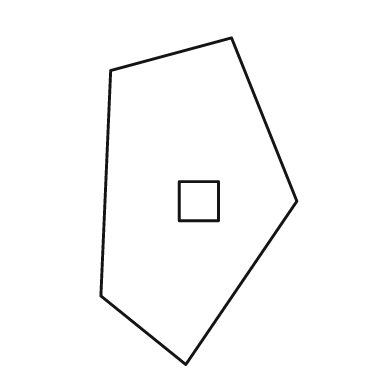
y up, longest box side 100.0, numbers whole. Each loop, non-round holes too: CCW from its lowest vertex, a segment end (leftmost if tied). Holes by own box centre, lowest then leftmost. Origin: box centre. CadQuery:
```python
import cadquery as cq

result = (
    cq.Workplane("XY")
    .moveTo(-4.0, -50.0)
    .lineTo(30.0, 0.0)
    .lineTo(10.0, 50.0)
    .lineTo(-27.0, 40.0)
    .lineTo(-30.0, -29.0)
    .close()
    .moveTo(-6.0, -6.0)
    .lineTo(6.0, -6.0)
    .lineTo(6.0, 6.0)
    .lineTo(-6.0, 6.0)
    .close()
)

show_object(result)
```